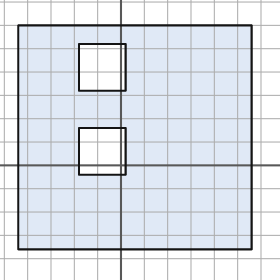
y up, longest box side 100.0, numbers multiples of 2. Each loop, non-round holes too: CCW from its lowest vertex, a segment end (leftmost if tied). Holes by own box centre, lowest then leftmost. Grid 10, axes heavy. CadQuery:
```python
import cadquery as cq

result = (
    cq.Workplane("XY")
    .moveTo(-44.0, -36.0)
    .lineTo(56.0, -36.0)
    .lineTo(56.0, 60.0)
    .lineTo(-44.0, 60.0)
    .close()
    .moveTo(-18.0, -4.0)
    .lineTo(2.0, -4.0)
    .lineTo(2.0, 16.0)
    .lineTo(-18.0, 16.0)
    .close()
    .moveTo(-18.0, 32.0)
    .lineTo(2.0, 32.0)
    .lineTo(2.0, 52.0)
    .lineTo(-18.0, 52.0)
    .close()
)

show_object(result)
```